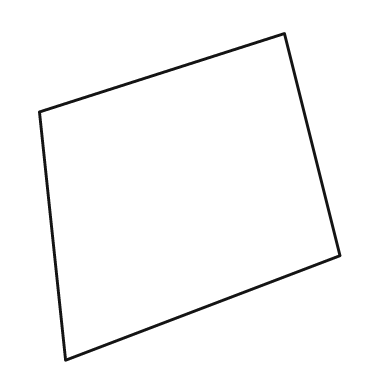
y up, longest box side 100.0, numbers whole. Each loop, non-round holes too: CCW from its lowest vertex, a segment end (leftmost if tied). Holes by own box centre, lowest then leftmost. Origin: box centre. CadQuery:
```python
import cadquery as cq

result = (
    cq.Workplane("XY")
    .moveTo(-38.0, -50.0)
    .lineTo(46.0, -18.0)
    .lineTo(29.0, 50.0)
    .lineTo(-46.0, 26.0)
    .close()
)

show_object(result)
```